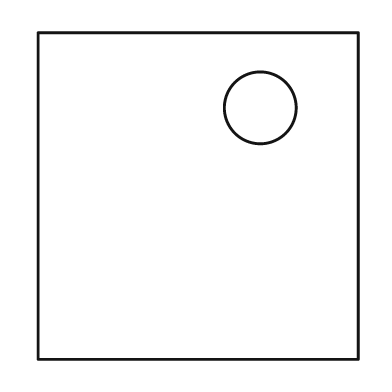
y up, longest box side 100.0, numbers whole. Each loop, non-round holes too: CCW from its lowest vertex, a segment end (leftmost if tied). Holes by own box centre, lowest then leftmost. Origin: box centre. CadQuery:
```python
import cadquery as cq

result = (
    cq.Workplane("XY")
    .moveTo(-49.0, -50.0)
    .lineTo(49.0, -50.0)
    .lineTo(49.0, 50.0)
    .lineTo(-49.0, 50.0)
    .close()
    .moveTo(19.0, 27.0)
    .circle(11.0)
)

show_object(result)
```